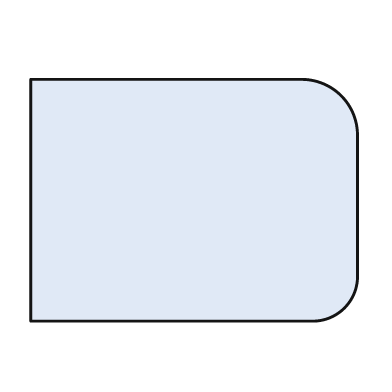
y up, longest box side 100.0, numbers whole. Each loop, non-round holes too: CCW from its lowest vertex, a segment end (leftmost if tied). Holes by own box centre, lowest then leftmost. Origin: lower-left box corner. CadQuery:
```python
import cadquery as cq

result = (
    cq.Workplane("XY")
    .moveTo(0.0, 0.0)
    .lineTo(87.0, 0.0)
    .threePointArc((96.0, 4.0), (100.0, 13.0))
    .lineTo(100.0, 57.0)
    .threePointArc((95.0, 69.0), (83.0, 74.0))
    .lineTo(0.0, 74.0)
    .close()
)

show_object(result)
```